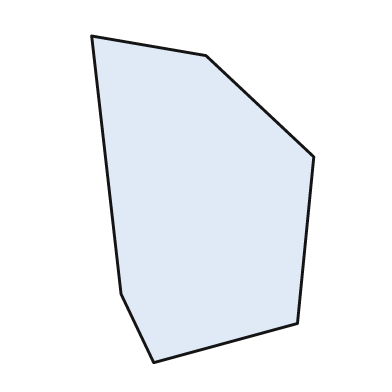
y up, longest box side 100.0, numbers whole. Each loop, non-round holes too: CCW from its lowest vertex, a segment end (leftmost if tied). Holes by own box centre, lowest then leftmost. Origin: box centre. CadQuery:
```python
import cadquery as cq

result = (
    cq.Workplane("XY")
    .moveTo(-15.0, -50.0)
    .lineTo(29.0, -38.0)
    .lineTo(34.0, 13.0)
    .lineTo(1.0, 44.0)
    .lineTo(-34.0, 50.0)
    .lineTo(-25.0, -29.0)
    .close()
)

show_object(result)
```